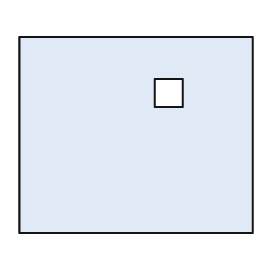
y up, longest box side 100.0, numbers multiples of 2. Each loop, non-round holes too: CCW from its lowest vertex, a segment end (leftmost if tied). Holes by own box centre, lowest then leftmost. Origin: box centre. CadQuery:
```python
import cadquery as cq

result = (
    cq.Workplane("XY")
    .moveTo(-50.0, -42.0)
    .lineTo(50.0, -42.0)
    .lineTo(50.0, 42.0)
    .lineTo(-50.0, 42.0)
    .close()
    .moveTo(8.0, 12.0)
    .lineTo(20.0, 12.0)
    .lineTo(20.0, 24.0)
    .lineTo(8.0, 24.0)
    .close()
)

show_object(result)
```